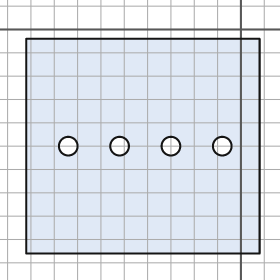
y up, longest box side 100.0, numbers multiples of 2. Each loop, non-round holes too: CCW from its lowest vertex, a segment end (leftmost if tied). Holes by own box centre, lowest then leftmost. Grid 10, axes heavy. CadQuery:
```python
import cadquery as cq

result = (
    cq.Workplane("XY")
    .moveTo(-92.0, -96.0)
    .lineTo(8.0, -96.0)
    .lineTo(8.0, -4.0)
    .lineTo(-92.0, -4.0)
    .close()
    .moveTo(-74.0, -50.0)
    .circle(4.0)
    .moveTo(-52.0, -50.0)
    .circle(4.0)
    .moveTo(-30.0, -50.0)
    .circle(4.0)
    .moveTo(-8.0, -50.0)
    .circle(4.0)
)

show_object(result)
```